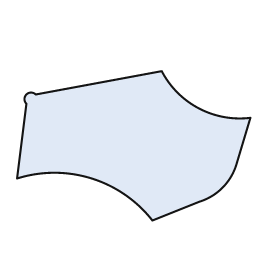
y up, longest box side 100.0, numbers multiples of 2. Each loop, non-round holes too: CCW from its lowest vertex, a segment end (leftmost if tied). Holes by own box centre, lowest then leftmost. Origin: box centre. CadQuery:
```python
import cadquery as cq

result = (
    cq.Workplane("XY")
    .moveTo(8.0, -32.0)
    .lineTo(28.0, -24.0)
    .threePointArc((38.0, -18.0), (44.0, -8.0))
    .lineTo(50.0, 12.0)
    .threePointArc((28.0, 16.0), (12.0, 32.0))
    .lineTo(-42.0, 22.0)
    .threePointArc((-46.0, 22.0), (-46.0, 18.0))
    .lineTo(-50.0, -14.0)
    .threePointArc((-18.0, -14.0), (8.0, -32.0))
    .close()
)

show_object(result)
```